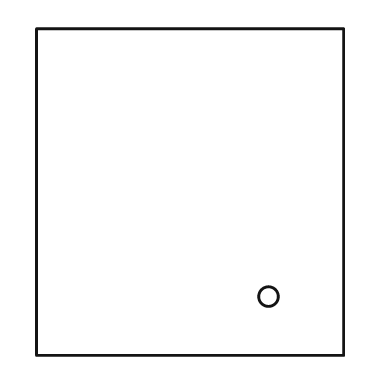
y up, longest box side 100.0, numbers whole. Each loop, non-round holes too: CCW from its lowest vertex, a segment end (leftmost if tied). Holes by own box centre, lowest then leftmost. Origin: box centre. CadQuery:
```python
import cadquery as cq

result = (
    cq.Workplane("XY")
    .moveTo(-47.0, -50.0)
    .lineTo(47.0, -50.0)
    .lineTo(47.0, 50.0)
    .lineTo(-47.0, 50.0)
    .close()
    .moveTo(24.0, -32.0)
    .circle(3.0)
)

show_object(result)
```